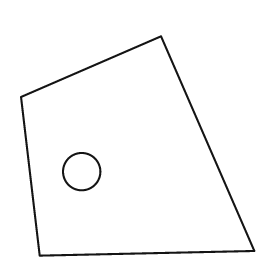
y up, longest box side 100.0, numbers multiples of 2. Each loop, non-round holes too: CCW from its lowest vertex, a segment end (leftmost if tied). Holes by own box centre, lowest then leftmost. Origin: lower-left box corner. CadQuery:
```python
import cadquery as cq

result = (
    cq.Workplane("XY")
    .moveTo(8.0, 0.0)
    .lineTo(100.0, 2.0)
    .lineTo(60.0, 94.0)
    .lineTo(0.0, 68.0)
    .close()
    .moveTo(26.0, 36.0)
    .circle(8.0)
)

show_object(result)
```